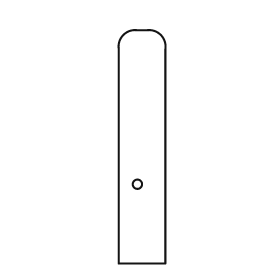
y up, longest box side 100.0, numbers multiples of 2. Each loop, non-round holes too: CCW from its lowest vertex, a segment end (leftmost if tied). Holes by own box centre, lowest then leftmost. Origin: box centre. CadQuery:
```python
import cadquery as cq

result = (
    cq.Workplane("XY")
    .moveTo(-10.0, -50.0)
    .lineTo(10.0, -50.0)
    .lineTo(10.0, 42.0)
    .threePointArc((8.0, 48.0), (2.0, 50.0))
    .lineTo(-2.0, 50.0)
    .threePointArc((-8.0, 48.0), (-10.0, 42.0))
    .close()
    .moveTo(-2.0, -16.0)
    .circle(2.0)
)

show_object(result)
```